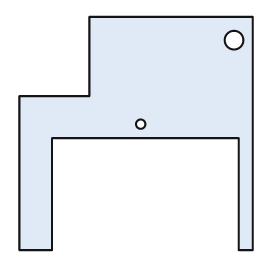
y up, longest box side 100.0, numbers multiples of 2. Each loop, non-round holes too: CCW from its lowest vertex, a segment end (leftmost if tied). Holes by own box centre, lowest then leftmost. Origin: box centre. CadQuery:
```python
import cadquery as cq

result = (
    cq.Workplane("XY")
    .moveTo(-50.0, -50.0)
    .lineTo(-36.0, -50.0)
    .lineTo(-36.0, -2.0)
    .lineTo(44.0, -2.0)
    .lineTo(44.0, -50.0)
    .lineTo(50.0, -50.0)
    .lineTo(50.0, 50.0)
    .lineTo(-20.0, 50.0)
    .lineTo(-20.0, 16.0)
    .lineTo(-50.0, 16.0)
    .close()
    .moveTo(2.0, 4.0)
    .circle(2.0)
    .moveTo(42.0, 40.0)
    .circle(4.0)
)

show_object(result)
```